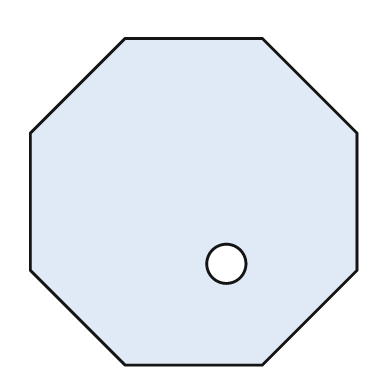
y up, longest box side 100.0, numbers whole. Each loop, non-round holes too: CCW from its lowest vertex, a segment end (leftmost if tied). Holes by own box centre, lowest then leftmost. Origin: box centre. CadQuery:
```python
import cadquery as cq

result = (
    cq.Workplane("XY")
    .moveTo(-21.0, -50.0)
    .lineTo(21.0, -50.0)
    .lineTo(50.0, -21.0)
    .lineTo(50.0, 21.0)
    .lineTo(21.0, 50.0)
    .lineTo(-21.0, 50.0)
    .lineTo(-50.0, 21.0)
    .lineTo(-50.0, -21.0)
    .close()
    .moveTo(10.0, -19.0)
    .circle(6.0)
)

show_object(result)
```